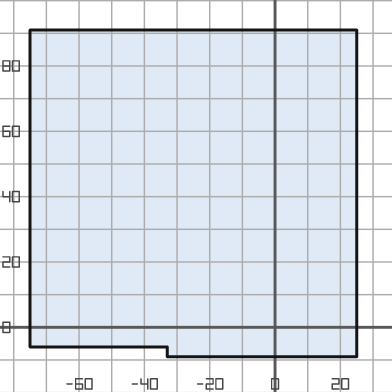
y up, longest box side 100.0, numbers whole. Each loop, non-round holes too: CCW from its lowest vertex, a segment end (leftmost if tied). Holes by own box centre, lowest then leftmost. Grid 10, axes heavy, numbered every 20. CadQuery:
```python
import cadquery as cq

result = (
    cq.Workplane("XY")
    .moveTo(-33.0, -9.0)
    .lineTo(25.0, -9.0)
    .lineTo(25.0, 91.0)
    .lineTo(-75.0, 91.0)
    .lineTo(-75.0, -6.0)
    .lineTo(-33.0, -6.0)
    .close()
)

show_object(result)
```